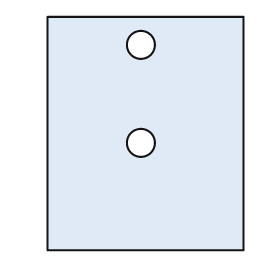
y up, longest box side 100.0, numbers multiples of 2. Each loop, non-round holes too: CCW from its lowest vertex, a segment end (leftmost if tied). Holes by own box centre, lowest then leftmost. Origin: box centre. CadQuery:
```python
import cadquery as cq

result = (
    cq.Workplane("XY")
    .moveTo(-42.0, -50.0)
    .lineTo(42.0, -50.0)
    .lineTo(42.0, 50.0)
    .lineTo(-42.0, 50.0)
    .close()
    .moveTo(-2.0, -4.0)
    .circle(6.0)
    .moveTo(-2.0, 38.0)
    .circle(6.0)
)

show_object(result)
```